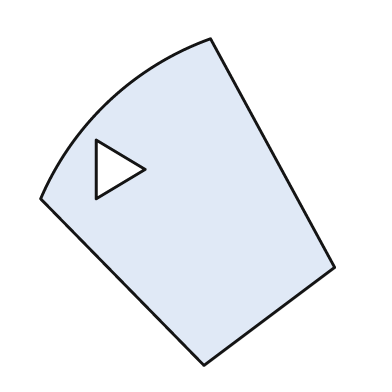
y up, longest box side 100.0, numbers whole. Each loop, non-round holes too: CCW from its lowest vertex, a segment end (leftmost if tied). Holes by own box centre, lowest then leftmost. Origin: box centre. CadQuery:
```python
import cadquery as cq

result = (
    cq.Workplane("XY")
    .moveTo(5.0, -50.0)
    .lineTo(45.0, -20.0)
    .lineTo(7.0, 50.0)
    .threePointArc((-24.0, 31.0), (-45.0, 1.0))
    .close()
    .moveTo(-28.0, 1.0)
    .lineTo(-13.0, 10.0)
    .lineTo(-28.0, 19.0)
    .close()
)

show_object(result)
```